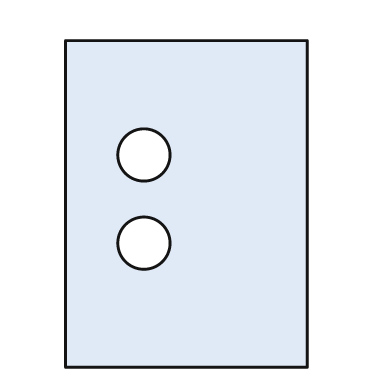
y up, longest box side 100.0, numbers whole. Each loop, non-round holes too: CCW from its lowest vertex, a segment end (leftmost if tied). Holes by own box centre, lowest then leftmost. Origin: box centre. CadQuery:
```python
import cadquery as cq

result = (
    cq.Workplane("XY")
    .moveTo(-37.0, -50.0)
    .lineTo(37.0, -50.0)
    .lineTo(37.0, 50.0)
    .lineTo(-37.0, 50.0)
    .close()
    .moveTo(-13.0, -12.0)
    .circle(8.0)
    .moveTo(-13.0, 15.0)
    .circle(8.0)
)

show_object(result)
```